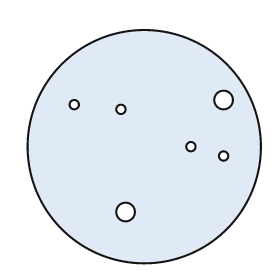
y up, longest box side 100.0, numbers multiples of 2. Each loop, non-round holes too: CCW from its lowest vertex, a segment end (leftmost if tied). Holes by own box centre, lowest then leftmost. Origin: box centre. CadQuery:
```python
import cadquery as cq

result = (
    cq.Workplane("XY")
    .moveTo(0.0, 0.0)
    .circle(50.0)
    .moveTo(-8.0, -28.0)
    .circle(4.0)
    .moveTo(34.0, -4.0)
    .circle(2.0)
    .moveTo(20.0, 0.0)
    .circle(2.0)
    .moveTo(-10.0, 16.0)
    .circle(2.0)
    .moveTo(-30.0, 18.0)
    .circle(2.0)
    .moveTo(34.0, 20.0)
    .circle(4.0)
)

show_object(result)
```